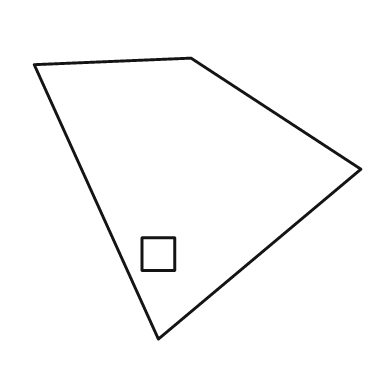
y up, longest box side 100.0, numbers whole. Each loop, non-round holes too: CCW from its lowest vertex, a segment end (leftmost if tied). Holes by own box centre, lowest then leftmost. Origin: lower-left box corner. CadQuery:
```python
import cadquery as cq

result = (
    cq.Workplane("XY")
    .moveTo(38.0, 0.0)
    .lineTo(100.0, 52.0)
    .lineTo(48.0, 86.0)
    .lineTo(0.0, 84.0)
    .close()
    .moveTo(33.0, 21.0)
    .lineTo(43.0, 21.0)
    .lineTo(43.0, 31.0)
    .lineTo(33.0, 31.0)
    .close()
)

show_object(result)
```